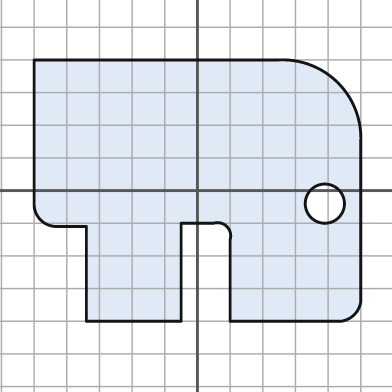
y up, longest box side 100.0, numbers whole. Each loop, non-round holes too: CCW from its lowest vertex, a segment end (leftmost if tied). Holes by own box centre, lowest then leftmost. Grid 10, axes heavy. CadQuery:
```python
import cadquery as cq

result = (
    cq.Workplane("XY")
    .moveTo(-34.0, -40.0)
    .lineTo(-5.0, -40.0)
    .lineTo(-5.0, -10.0)
    .lineTo(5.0, -10.0)
    .threePointArc((9.0, -11.0), (10.0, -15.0))
    .lineTo(10.0, -40.0)
    .lineTo(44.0, -40.0)
    .threePointArc((48.0, -38.0), (50.0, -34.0))
    .lineTo(50.0, 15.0)
    .threePointArc((43.0, 33.0), (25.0, 40.0))
    .lineTo(-50.0, 40.0)
    .lineTo(-50.0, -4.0)
    .threePointArc((-48.0, -9.0), (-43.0, -11.0))
    .lineTo(-34.0, -11.0)
    .close()
    .moveTo(39.0, -4.0)
    .circle(6.0)
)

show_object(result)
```